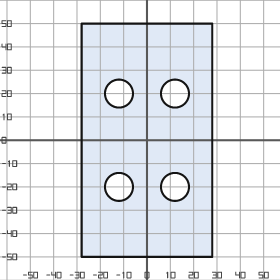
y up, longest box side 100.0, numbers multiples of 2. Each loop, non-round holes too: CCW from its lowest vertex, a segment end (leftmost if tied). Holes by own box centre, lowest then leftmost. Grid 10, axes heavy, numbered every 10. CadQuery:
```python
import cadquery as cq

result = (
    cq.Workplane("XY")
    .moveTo(-28.0, -50.0)
    .lineTo(28.0, -50.0)
    .lineTo(28.0, 50.0)
    .lineTo(-28.0, 50.0)
    .close()
    .moveTo(-12.0, -20.0)
    .circle(6.0)
    .moveTo(12.0, -20.0)
    .circle(6.0)
    .moveTo(-12.0, 20.0)
    .circle(6.0)
    .moveTo(12.0, 20.0)
    .circle(6.0)
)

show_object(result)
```